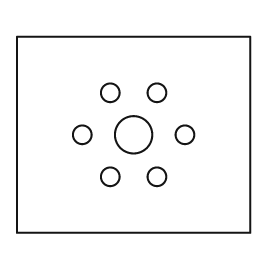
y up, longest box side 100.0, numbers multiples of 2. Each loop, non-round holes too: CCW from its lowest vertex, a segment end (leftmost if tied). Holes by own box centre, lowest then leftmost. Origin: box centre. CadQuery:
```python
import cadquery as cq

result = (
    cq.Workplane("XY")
    .moveTo(-50.0, -42.0)
    .lineTo(50.0, -42.0)
    .lineTo(50.0, 42.0)
    .lineTo(-50.0, 42.0)
    .close()
    .moveTo(-10.0, -18.0)
    .circle(4.0)
    .moveTo(10.0, -18.0)
    .circle(4.0)
    .moveTo(-22.0, 0.0)
    .circle(4.0)
    .moveTo(0.0, 0.0)
    .circle(8.0)
    .moveTo(22.0, 0.0)
    .circle(4.0)
    .moveTo(-10.0, 18.0)
    .circle(4.0)
    .moveTo(10.0, 18.0)
    .circle(4.0)
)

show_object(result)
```